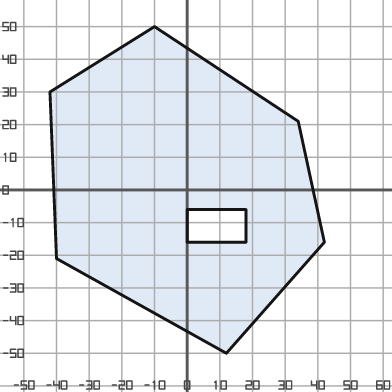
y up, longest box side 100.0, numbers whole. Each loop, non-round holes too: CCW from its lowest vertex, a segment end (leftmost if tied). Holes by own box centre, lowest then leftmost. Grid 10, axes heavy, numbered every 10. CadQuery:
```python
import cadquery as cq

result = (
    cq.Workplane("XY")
    .moveTo(12.0, -50.0)
    .lineTo(42.0, -16.0)
    .lineTo(34.0, 21.0)
    .lineTo(-10.0, 50.0)
    .lineTo(-42.0, 30.0)
    .lineTo(-40.0, -21.0)
    .close()
    .moveTo(0.0, -16.0)
    .lineTo(18.0, -16.0)
    .lineTo(18.0, -6.0)
    .lineTo(0.0, -6.0)
    .close()
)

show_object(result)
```